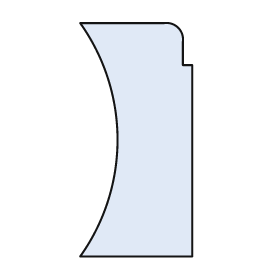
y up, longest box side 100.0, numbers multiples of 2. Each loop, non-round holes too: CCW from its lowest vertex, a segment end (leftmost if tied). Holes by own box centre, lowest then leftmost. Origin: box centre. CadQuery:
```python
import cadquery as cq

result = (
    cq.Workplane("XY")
    .moveTo(-24.0, -50.0)
    .lineTo(24.0, -50.0)
    .lineTo(24.0, 32.0)
    .lineTo(20.0, 32.0)
    .lineTo(20.0, 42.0)
    .threePointArc((18.0, 48.0), (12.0, 50.0))
    .lineTo(-24.0, 50.0)
    .threePointArc((-8.0, 0.0), (-24.0, -50.0))
    .close()
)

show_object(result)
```